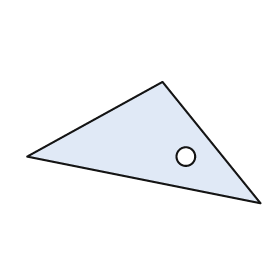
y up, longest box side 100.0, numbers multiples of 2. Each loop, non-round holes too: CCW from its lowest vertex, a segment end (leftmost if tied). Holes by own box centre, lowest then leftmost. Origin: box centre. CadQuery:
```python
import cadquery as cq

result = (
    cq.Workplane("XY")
    .moveTo(50.0, -26.0)
    .lineTo(8.0, 26.0)
    .lineTo(-50.0, -6.0)
    .close()
    .moveTo(18.0, -6.0)
    .circle(4.0)
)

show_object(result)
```